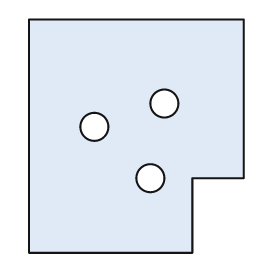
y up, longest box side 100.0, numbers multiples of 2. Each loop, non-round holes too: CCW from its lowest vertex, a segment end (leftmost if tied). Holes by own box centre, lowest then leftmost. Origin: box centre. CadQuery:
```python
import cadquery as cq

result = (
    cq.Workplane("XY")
    .moveTo(-46.0, -50.0)
    .lineTo(24.0, -50.0)
    .lineTo(24.0, -18.0)
    .lineTo(46.0, -18.0)
    .lineTo(46.0, 50.0)
    .lineTo(-46.0, 50.0)
    .close()
    .moveTo(6.0, -18.0)
    .circle(6.0)
    .moveTo(-18.0, 4.0)
    .circle(6.0)
    .moveTo(12.0, 14.0)
    .circle(6.0)
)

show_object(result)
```